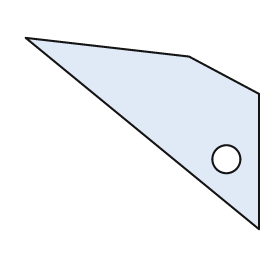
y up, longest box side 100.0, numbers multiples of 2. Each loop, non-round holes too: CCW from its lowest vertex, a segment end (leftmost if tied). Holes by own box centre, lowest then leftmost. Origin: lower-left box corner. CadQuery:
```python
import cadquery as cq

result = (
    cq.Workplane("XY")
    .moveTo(100.0, 0.0)
    .lineTo(100.0, 58.0)
    .lineTo(70.0, 74.0)
    .lineTo(0.0, 82.0)
    .close()
    .moveTo(86.0, 30.0)
    .circle(6.0)
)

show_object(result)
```